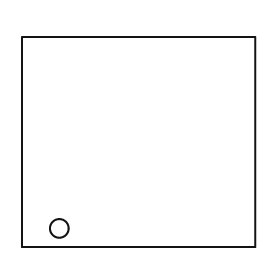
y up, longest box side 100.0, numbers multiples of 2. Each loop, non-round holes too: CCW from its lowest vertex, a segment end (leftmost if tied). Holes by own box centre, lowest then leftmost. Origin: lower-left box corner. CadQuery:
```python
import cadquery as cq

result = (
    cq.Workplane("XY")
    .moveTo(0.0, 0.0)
    .lineTo(100.0, 0.0)
    .lineTo(100.0, 90.0)
    .lineTo(0.0, 90.0)
    .close()
    .moveTo(16.0, 8.0)
    .circle(4.0)
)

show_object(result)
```